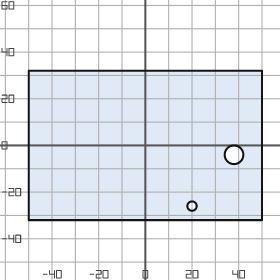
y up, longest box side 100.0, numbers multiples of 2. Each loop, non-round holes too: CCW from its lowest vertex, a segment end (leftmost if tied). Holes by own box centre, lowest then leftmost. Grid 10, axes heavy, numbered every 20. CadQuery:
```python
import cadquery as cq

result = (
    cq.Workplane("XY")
    .moveTo(-50.0, -32.0)
    .lineTo(50.0, -32.0)
    .lineTo(50.0, 32.0)
    .lineTo(-50.0, 32.0)
    .close()
    .moveTo(20.0, -26.0)
    .circle(2.0)
    .moveTo(38.0, -4.0)
    .circle(4.0)
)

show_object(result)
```